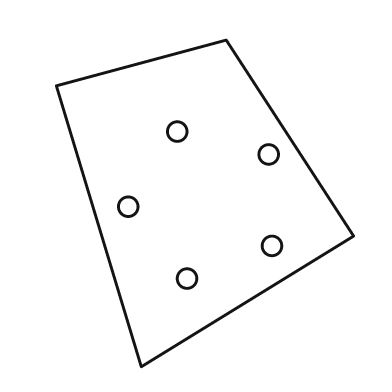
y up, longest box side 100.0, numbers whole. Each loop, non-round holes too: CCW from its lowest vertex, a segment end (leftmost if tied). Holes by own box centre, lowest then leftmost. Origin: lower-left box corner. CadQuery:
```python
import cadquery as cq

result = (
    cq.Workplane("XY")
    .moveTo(26.0, 0.0)
    .lineTo(91.0, 40.0)
    .lineTo(52.0, 100.0)
    .lineTo(0.0, 86.0)
    .close()
    .moveTo(40.0, 27.0)
    .circle(3.0)
    .moveTo(66.0, 37.0)
    .circle(3.0)
    .moveTo(22.0, 49.0)
    .circle(3.0)
    .moveTo(65.0, 65.0)
    .circle(3.0)
    .moveTo(37.0, 72.0)
    .circle(3.0)
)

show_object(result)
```